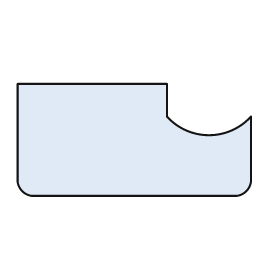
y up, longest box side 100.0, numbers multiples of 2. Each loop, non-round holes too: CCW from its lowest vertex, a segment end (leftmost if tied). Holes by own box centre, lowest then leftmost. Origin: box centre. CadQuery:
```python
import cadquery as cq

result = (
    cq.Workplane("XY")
    .moveTo(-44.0, -24.0)
    .lineTo(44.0, -24.0)
    .threePointArc((48.0, -22.0), (50.0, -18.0))
    .lineTo(50.0, 10.0)
    .threePointArc((32.0, 2.0), (14.0, 10.0))
    .lineTo(14.0, 24.0)
    .lineTo(-50.0, 24.0)
    .lineTo(-50.0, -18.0)
    .threePointArc((-48.0, -22.0), (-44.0, -24.0))
    .close()
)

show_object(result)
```